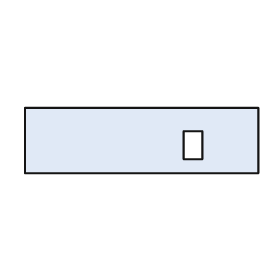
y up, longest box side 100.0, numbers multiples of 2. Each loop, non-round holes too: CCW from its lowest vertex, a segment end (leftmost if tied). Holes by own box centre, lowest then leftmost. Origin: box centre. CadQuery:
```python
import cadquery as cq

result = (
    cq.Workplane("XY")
    .moveTo(-50.0, -14.0)
    .lineTo(50.0, -14.0)
    .lineTo(50.0, 14.0)
    .lineTo(-50.0, 14.0)
    .close()
    .moveTo(18.0, -8.0)
    .lineTo(26.0, -8.0)
    .lineTo(26.0, 4.0)
    .lineTo(18.0, 4.0)
    .close()
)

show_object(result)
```